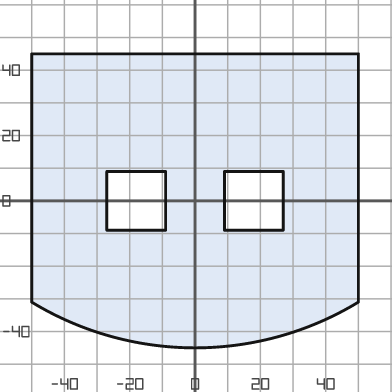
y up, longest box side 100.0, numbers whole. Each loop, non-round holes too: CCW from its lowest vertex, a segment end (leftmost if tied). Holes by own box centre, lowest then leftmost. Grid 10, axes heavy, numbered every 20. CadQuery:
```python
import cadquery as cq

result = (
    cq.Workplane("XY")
    .moveTo(-50.0, -31.0)
    .threePointArc((0.0, -45.0), (50.0, -31.0))
    .lineTo(50.0, 45.0)
    .lineTo(-50.0, 45.0)
    .close()
    .moveTo(-27.0, -9.0)
    .lineTo(-9.0, -9.0)
    .lineTo(-9.0, 9.0)
    .lineTo(-27.0, 9.0)
    .close()
    .moveTo(9.0, -9.0)
    .lineTo(27.0, -9.0)
    .lineTo(27.0, 9.0)
    .lineTo(9.0, 9.0)
    .close()
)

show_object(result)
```